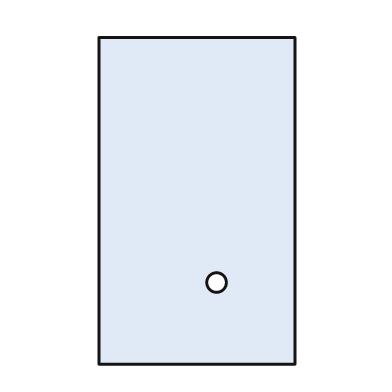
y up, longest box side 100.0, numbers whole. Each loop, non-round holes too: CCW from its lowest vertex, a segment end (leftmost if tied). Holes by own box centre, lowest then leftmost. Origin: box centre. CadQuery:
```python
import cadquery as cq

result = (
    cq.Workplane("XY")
    .moveTo(-30.0, -50.0)
    .lineTo(30.0, -50.0)
    .lineTo(30.0, 50.0)
    .lineTo(-30.0, 50.0)
    .close()
    .moveTo(6.0, -25.0)
    .circle(3.0)
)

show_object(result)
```